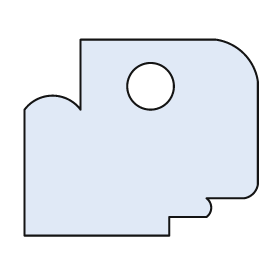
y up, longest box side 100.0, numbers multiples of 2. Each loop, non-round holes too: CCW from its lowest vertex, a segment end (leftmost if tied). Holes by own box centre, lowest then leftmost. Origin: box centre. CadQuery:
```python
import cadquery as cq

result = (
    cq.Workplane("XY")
    .moveTo(-50.0, -42.0)
    .lineTo(12.0, -42.0)
    .lineTo(12.0, -34.0)
    .lineTo(28.0, -34.0)
    .threePointArc((30.0, -30.0), (28.0, -26.0))
    .lineTo(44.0, -26.0)
    .threePointArc((48.0, -24.0), (50.0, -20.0))
    .lineTo(50.0, 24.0)
    .threePointArc((44.0, 36.0), (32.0, 42.0))
    .lineTo(-26.0, 42.0)
    .lineTo(-26.0, 12.0)
    .threePointArc((-38.0, 18.0), (-50.0, 12.0))
    .close()
    .moveTo(4.0, 22.0)
    .circle(10.0)
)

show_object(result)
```